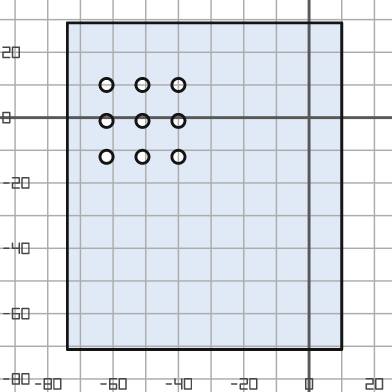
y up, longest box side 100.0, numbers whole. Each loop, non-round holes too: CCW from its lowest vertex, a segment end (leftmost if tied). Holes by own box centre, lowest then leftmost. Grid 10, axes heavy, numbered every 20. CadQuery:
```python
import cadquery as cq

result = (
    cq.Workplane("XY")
    .moveTo(-74.0, -71.0)
    .lineTo(10.0, -71.0)
    .lineTo(10.0, 29.0)
    .lineTo(-74.0, 29.0)
    .close()
    .moveTo(-62.0, -12.0)
    .circle(2.0)
    .moveTo(-51.0, -12.0)
    .circle(2.0)
    .moveTo(-40.0, -12.0)
    .circle(2.0)
    .moveTo(-62.0, -1.0)
    .circle(2.0)
    .moveTo(-51.0, -1.0)
    .circle(2.0)
    .moveTo(-40.0, -1.0)
    .circle(2.0)
    .moveTo(-62.0, 10.0)
    .circle(2.0)
    .moveTo(-51.0, 10.0)
    .circle(2.0)
    .moveTo(-40.0, 10.0)
    .circle(2.0)
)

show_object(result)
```